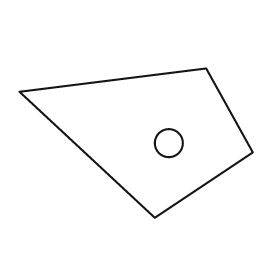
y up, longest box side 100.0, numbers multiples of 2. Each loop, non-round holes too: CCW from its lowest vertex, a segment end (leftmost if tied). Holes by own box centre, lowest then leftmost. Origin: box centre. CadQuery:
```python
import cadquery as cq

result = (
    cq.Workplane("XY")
    .moveTo(8.0, -32.0)
    .lineTo(50.0, -4.0)
    .lineTo(30.0, 32.0)
    .lineTo(-50.0, 22.0)
    .close()
    .moveTo(14.0, 0.0)
    .circle(6.0)
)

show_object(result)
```